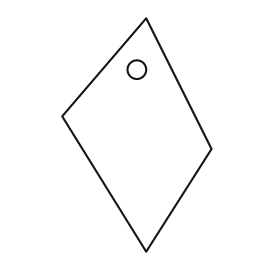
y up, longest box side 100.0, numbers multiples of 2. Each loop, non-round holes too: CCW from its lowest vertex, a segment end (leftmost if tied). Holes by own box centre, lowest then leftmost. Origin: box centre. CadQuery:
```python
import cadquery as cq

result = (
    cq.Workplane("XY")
    .moveTo(4.0, -50.0)
    .lineTo(32.0, -6.0)
    .lineTo(4.0, 50.0)
    .lineTo(-32.0, 8.0)
    .close()
    .moveTo(0.0, 28.0)
    .circle(4.0)
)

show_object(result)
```